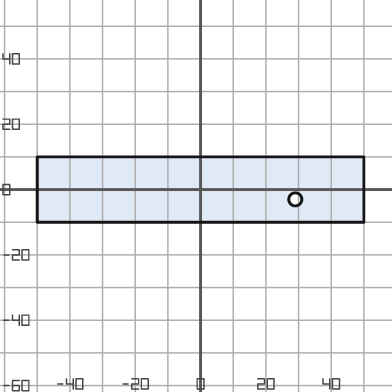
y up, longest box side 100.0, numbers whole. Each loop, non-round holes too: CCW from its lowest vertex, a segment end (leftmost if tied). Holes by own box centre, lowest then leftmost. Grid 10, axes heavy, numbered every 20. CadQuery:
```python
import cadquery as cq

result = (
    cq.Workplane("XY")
    .moveTo(-50.0, -10.0)
    .lineTo(50.0, -10.0)
    .lineTo(50.0, 10.0)
    .lineTo(-50.0, 10.0)
    .close()
    .moveTo(29.0, -3.0)
    .circle(2.0)
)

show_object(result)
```